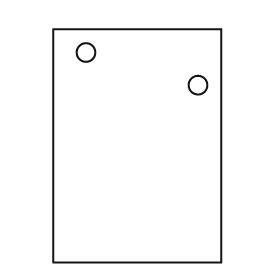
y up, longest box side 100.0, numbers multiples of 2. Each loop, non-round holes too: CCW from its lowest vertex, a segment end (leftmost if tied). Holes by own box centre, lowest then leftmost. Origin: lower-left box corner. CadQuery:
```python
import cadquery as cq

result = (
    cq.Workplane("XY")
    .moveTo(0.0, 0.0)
    .lineTo(72.0, 0.0)
    .lineTo(72.0, 100.0)
    .lineTo(0.0, 100.0)
    .close()
    .moveTo(62.0, 76.0)
    .circle(4.0)
    .moveTo(14.0, 90.0)
    .circle(4.0)
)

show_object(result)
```